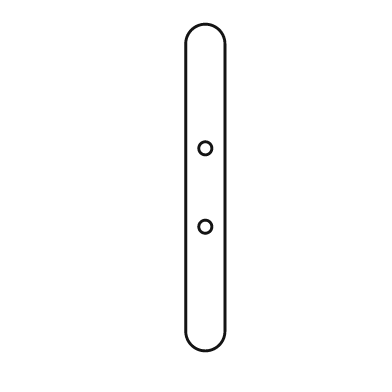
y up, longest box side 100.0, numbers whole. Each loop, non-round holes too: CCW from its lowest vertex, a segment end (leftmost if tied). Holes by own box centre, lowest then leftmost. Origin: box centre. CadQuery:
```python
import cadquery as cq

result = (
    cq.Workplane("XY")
    .moveTo(-6.0, -44.0)
    .threePointArc((0.0, -50.0), (6.0, -44.0))
    .lineTo(6.0, 44.0)
    .threePointArc((0.0, 50.0), (-6.0, 44.0))
    .close()
    .moveTo(0.0, -12.0)
    .circle(2.0)
    .moveTo(0.0, 12.0)
    .circle(2.0)
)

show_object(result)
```